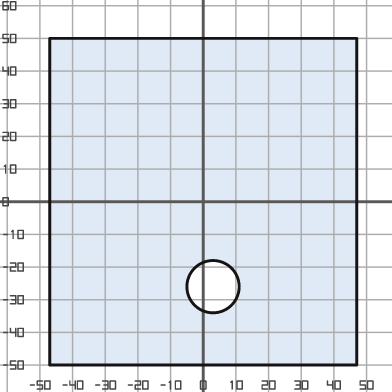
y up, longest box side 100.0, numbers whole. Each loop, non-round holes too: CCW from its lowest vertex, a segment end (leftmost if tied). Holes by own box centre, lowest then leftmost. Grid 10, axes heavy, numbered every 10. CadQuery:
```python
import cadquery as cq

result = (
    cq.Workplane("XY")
    .moveTo(-47.0, -50.0)
    .lineTo(47.0, -50.0)
    .lineTo(47.0, 50.0)
    .lineTo(-47.0, 50.0)
    .close()
    .moveTo(3.0, -26.0)
    .circle(8.0)
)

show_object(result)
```